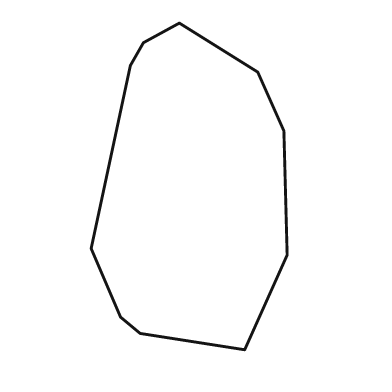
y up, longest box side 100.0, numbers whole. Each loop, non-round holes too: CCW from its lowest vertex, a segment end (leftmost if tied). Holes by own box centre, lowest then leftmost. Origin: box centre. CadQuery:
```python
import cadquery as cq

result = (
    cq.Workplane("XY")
    .moveTo(17.0, -50.0)
    .lineTo(30.0, -21.0)
    .lineTo(29.0, 17.0)
    .lineTo(21.0, 35.0)
    .lineTo(-3.0, 50.0)
    .lineTo(-14.0, 44.0)
    .lineTo(-18.0, 37.0)
    .lineTo(-30.0, -19.0)
    .lineTo(-21.0, -40.0)
    .lineTo(-15.0, -45.0)
    .close()
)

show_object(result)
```